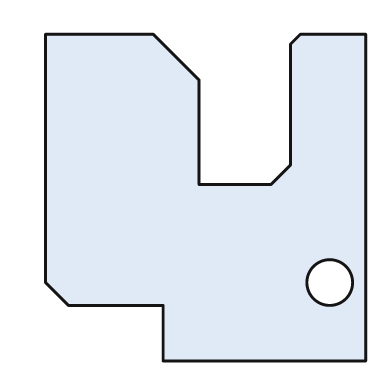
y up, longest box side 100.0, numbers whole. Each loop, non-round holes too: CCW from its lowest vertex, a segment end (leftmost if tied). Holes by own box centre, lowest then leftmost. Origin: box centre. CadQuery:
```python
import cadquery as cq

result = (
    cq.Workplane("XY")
    .moveTo(-13.0, -50.0)
    .lineTo(49.0, -50.0)
    .lineTo(49.0, 50.0)
    .lineTo(29.0, 50.0)
    .lineTo(26.0, 47.0)
    .lineTo(26.0, 10.0)
    .lineTo(20.0, 4.0)
    .lineTo(-2.0, 4.0)
    .lineTo(-2.0, 36.0)
    .lineTo(-16.0, 50.0)
    .lineTo(-49.0, 50.0)
    .lineTo(-49.0, -26.0)
    .lineTo(-42.0, -33.0)
    .lineTo(-13.0, -33.0)
    .close()
    .moveTo(38.0, -26.0)
    .circle(7.0)
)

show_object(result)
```